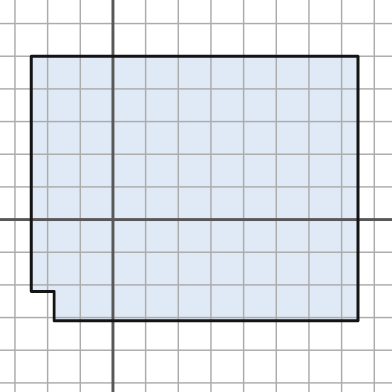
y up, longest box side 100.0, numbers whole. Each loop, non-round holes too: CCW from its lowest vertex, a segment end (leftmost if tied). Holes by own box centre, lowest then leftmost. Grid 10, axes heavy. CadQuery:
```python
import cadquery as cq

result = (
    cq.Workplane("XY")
    .moveTo(-18.0, -31.0)
    .lineTo(75.0, -31.0)
    .lineTo(75.0, 50.0)
    .lineTo(-25.0, 50.0)
    .lineTo(-25.0, -22.0)
    .lineTo(-18.0, -22.0)
    .close()
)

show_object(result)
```